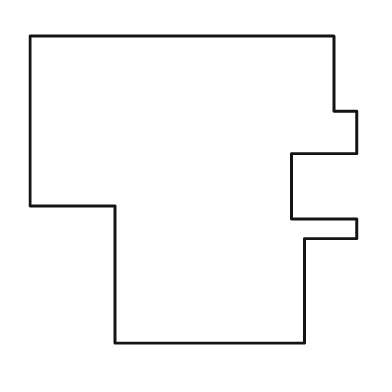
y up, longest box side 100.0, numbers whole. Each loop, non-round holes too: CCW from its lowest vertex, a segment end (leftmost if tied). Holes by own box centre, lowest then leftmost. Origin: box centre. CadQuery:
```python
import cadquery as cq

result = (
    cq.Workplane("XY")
    .moveTo(-24.0, -47.0)
    .lineTo(34.0, -47.0)
    .lineTo(34.0, -15.0)
    .lineTo(50.0, -15.0)
    .lineTo(50.0, -9.0)
    .lineTo(30.0, -9.0)
    .lineTo(30.0, 11.0)
    .lineTo(50.0, 11.0)
    .lineTo(50.0, 24.0)
    .lineTo(43.0, 24.0)
    .lineTo(43.0, 47.0)
    .lineTo(-50.0, 47.0)
    .lineTo(-50.0, -5.0)
    .lineTo(-24.0, -5.0)
    .close()
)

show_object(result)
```